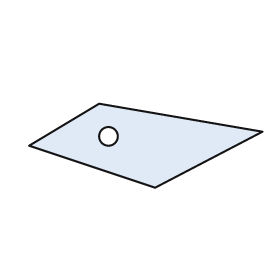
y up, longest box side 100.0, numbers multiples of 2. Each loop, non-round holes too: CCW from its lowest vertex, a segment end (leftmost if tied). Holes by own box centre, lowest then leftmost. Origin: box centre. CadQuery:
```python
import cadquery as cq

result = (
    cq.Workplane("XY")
    .moveTo(4.0, -18.0)
    .lineTo(50.0, 6.0)
    .lineTo(-20.0, 18.0)
    .lineTo(-50.0, 0.0)
    .close()
    .moveTo(-16.0, 4.0)
    .circle(4.0)
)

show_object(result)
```